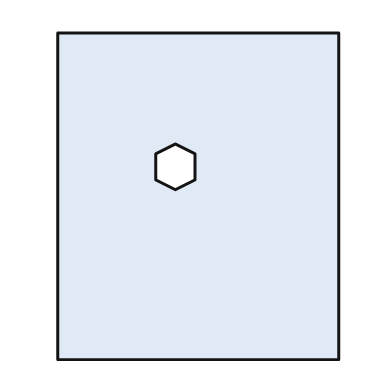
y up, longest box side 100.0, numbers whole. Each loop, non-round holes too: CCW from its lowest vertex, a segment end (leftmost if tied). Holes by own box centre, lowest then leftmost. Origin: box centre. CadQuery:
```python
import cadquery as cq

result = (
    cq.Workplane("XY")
    .moveTo(-43.0, -50.0)
    .lineTo(43.0, -50.0)
    .lineTo(43.0, 50.0)
    .lineTo(-43.0, 50.0)
    .close()
    .moveTo(-7.0, 2.0)
    .lineTo(-1.0, 5.0)
    .lineTo(-1.0, 13.0)
    .lineTo(-7.0, 16.0)
    .lineTo(-13.0, 13.0)
    .lineTo(-13.0, 5.0)
    .close()
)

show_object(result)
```